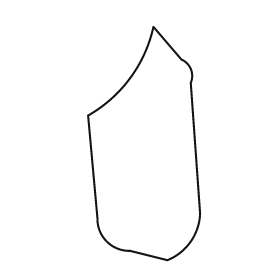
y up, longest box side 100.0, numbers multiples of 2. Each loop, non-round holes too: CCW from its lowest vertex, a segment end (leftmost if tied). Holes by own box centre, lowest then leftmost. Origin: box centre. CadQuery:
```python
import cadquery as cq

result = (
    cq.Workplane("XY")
    .moveTo(10.0, -50.0)
    .threePointArc((20.0, -42.0), (24.0, -30.0))
    .lineTo(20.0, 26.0)
    .threePointArc((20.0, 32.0), (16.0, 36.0))
    .lineTo(4.0, 50.0)
    .threePointArc((-6.0, 28.0), (-24.0, 12.0))
    .lineTo(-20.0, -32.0)
    .threePointArc((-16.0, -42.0), (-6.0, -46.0))
    .close()
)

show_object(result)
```